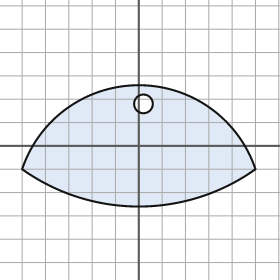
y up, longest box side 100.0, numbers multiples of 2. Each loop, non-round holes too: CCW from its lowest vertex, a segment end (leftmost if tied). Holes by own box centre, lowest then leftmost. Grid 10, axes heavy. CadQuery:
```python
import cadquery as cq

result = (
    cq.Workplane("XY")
    .moveTo(-50.0, -10.0)
    .threePointArc((0.0, -26.0), (50.0, -10.0))
    .threePointArc((0.0, 26.0), (-50.0, -10.0))
    .close()
    .moveTo(2.0, 18.0)
    .circle(4.0)
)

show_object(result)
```